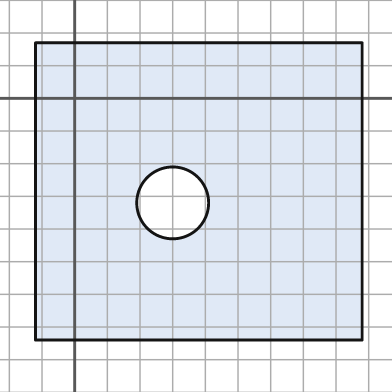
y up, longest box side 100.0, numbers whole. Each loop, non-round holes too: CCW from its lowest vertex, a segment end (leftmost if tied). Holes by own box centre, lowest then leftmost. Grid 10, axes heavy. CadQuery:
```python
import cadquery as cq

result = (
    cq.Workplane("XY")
    .moveTo(-12.0, -74.0)
    .lineTo(88.0, -74.0)
    .lineTo(88.0, 17.0)
    .lineTo(-12.0, 17.0)
    .close()
    .moveTo(30.0, -32.0)
    .circle(11.0)
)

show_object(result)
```